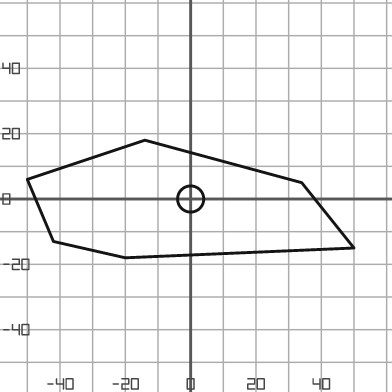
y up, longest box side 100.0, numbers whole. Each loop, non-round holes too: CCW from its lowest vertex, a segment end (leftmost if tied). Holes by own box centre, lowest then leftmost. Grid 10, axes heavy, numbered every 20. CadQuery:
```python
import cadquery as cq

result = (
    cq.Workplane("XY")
    .moveTo(-20.0, -18.0)
    .lineTo(50.0, -15.0)
    .lineTo(34.0, 5.0)
    .lineTo(-14.0, 18.0)
    .lineTo(-50.0, 6.0)
    .lineTo(-42.0, -13.0)
    .close()
    .moveTo(0.0, 0.0)
    .circle(4.0)
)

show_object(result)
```